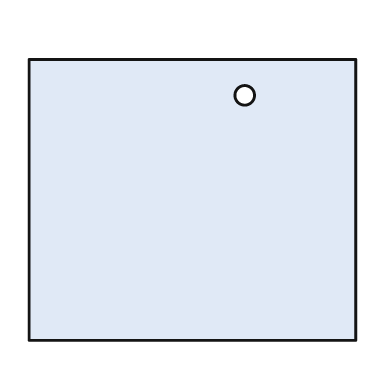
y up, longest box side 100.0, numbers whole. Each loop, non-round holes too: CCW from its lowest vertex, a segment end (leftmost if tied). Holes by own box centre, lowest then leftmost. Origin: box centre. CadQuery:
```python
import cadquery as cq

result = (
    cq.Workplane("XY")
    .moveTo(-50.0, -43.0)
    .lineTo(50.0, -43.0)
    .lineTo(50.0, 43.0)
    .lineTo(-50.0, 43.0)
    .close()
    .moveTo(16.0, 32.0)
    .circle(3.0)
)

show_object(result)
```